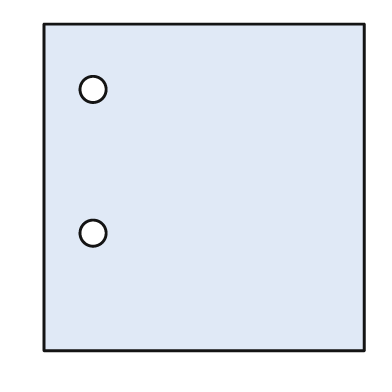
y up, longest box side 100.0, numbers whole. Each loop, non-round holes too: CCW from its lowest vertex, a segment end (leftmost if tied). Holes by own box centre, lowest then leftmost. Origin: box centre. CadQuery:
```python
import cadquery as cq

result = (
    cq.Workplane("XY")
    .moveTo(-49.0, -50.0)
    .lineTo(49.0, -50.0)
    .lineTo(49.0, 50.0)
    .lineTo(-49.0, 50.0)
    .close()
    .moveTo(-34.0, -14.0)
    .circle(4.0)
    .moveTo(-34.0, 30.0)
    .circle(4.0)
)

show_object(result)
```